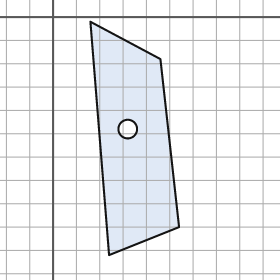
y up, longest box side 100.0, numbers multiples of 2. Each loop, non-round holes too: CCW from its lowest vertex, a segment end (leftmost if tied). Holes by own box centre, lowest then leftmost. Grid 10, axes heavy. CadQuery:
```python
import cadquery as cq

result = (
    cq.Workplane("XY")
    .moveTo(24.0, -102.0)
    .lineTo(54.0, -90.0)
    .lineTo(46.0, -18.0)
    .lineTo(16.0, -2.0)
    .close()
    .moveTo(32.0, -48.0)
    .circle(4.0)
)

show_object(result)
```